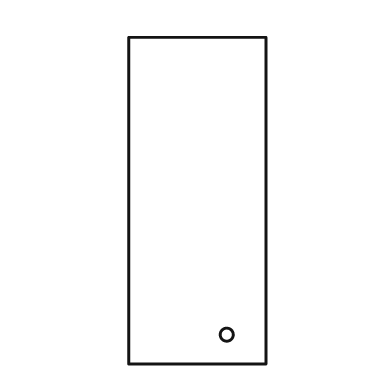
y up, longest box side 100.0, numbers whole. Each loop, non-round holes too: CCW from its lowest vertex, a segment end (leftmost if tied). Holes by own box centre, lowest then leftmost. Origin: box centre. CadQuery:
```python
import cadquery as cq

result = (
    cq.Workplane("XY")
    .moveTo(-21.0, -50.0)
    .lineTo(21.0, -50.0)
    .lineTo(21.0, 50.0)
    .lineTo(-21.0, 50.0)
    .close()
    .moveTo(9.0, -41.0)
    .circle(2.0)
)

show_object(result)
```